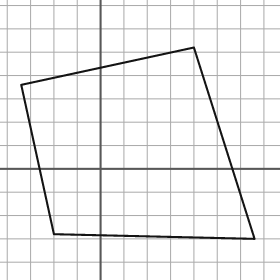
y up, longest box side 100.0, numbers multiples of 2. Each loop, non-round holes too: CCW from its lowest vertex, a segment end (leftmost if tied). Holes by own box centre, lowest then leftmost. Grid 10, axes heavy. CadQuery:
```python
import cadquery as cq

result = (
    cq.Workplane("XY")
    .moveTo(66.0, -30.0)
    .lineTo(40.0, 52.0)
    .lineTo(-34.0, 36.0)
    .lineTo(-20.0, -28.0)
    .close()
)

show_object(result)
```